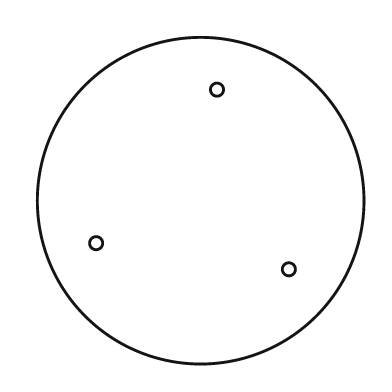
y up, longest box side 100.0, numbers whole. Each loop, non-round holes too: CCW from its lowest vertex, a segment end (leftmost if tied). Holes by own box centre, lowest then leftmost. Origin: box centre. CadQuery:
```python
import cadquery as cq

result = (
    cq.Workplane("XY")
    .moveTo(0.0, 0.0)
    .circle(50.0)
    .moveTo(27.0, -21.0)
    .circle(2.0)
    .moveTo(-32.0, -13.0)
    .circle(2.0)
    .moveTo(5.0, 34.0)
    .circle(2.0)
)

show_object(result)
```